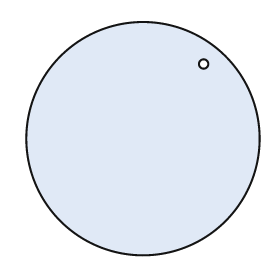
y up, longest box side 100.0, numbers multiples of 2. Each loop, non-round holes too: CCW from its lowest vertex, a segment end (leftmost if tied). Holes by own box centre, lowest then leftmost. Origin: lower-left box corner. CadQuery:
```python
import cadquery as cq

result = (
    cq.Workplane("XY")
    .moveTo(50.0, 50.0)
    .circle(50.0)
    .moveTo(76.0, 82.0)
    .circle(2.0)
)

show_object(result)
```